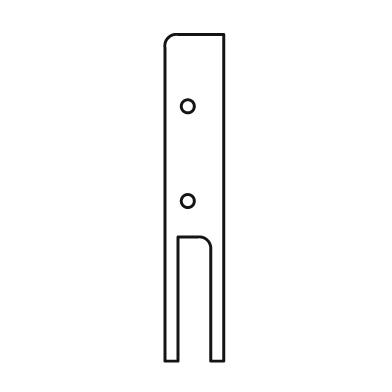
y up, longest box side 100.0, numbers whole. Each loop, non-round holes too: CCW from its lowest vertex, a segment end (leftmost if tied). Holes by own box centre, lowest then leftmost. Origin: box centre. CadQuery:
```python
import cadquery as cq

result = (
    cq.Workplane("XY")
    .moveTo(-9.0, -50.0)
    .lineTo(-5.0, -50.0)
    .lineTo(-5.0, -12.0)
    .lineTo(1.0, -12.0)
    .threePointArc((4.0, -13.0), (5.0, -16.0))
    .lineTo(5.0, -50.0)
    .lineTo(9.0, -50.0)
    .lineTo(9.0, 50.0)
    .lineTo(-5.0, 50.0)
    .threePointArc((-8.0, 49.0), (-9.0, 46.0))
    .close()
    .moveTo(-2.0, -1.0)
    .circle(2.0)
    .moveTo(-2.0, 28.0)
    .circle(2.0)
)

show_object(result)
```